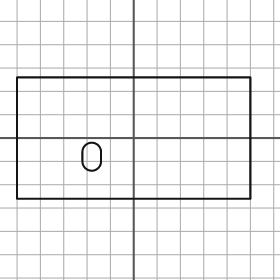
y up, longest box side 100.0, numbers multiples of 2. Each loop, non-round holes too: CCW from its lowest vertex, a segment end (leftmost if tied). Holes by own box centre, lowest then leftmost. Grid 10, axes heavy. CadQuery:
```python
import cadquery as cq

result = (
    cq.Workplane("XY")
    .moveTo(-50.0, -26.0)
    .lineTo(50.0, -26.0)
    .lineTo(50.0, 26.0)
    .lineTo(-50.0, 26.0)
    .close()
    .moveTo(-22.0, -10.0)
    .threePointArc((-18.0, -14.0), (-14.0, -10.0))
    .lineTo(-14.0, -6.0)
    .threePointArc((-18.0, -2.0), (-22.0, -6.0))
    .close()
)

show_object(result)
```